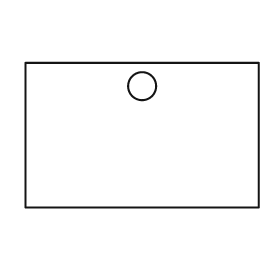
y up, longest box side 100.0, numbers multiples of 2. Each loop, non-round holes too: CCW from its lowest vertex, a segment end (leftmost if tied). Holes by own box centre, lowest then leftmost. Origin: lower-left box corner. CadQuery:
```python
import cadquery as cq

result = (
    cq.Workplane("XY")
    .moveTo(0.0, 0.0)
    .lineTo(100.0, 0.0)
    .lineTo(100.0, 62.0)
    .lineTo(0.0, 62.0)
    .close()
    .moveTo(50.0, 52.0)
    .circle(6.0)
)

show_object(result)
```